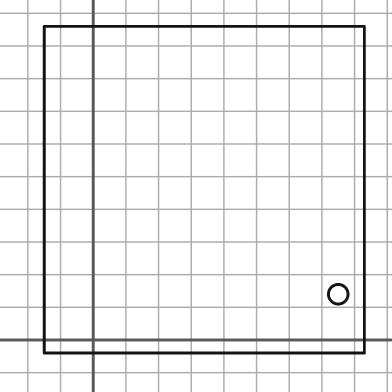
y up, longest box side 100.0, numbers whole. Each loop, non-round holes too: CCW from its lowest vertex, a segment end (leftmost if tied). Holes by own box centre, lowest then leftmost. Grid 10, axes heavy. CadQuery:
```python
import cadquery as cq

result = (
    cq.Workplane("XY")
    .moveTo(-15.0, -4.0)
    .lineTo(83.0, -4.0)
    .lineTo(83.0, 96.0)
    .lineTo(-15.0, 96.0)
    .close()
    .moveTo(75.0, 14.0)
    .circle(3.0)
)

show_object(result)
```